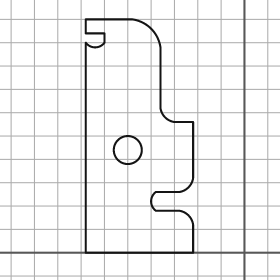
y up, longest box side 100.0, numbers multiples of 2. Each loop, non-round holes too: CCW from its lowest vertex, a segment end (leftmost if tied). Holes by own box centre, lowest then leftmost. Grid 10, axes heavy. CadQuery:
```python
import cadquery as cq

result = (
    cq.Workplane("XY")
    .moveTo(-68.0, 0.0)
    .lineTo(-22.0, 0.0)
    .lineTo(-22.0, 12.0)
    .threePointArc((-24.0, 16.0), (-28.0, 18.0))
    .lineTo(-38.0, 18.0)
    .threePointArc((-40.0, 22.0), (-38.0, 26.0))
    .lineTo(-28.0, 26.0)
    .threePointArc((-24.0, 28.0), (-22.0, 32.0))
    .lineTo(-22.0, 56.0)
    .lineTo(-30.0, 56.0)
    .threePointArc((-34.0, 58.0), (-36.0, 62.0))
    .lineTo(-36.0, 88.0)
    .threePointArc((-40.0, 96.0), (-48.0, 100.0))
    .lineTo(-68.0, 100.0)
    .lineTo(-68.0, 94.0)
    .lineTo(-60.0, 94.0)
    .lineTo(-60.0, 90.0)
    .threePointArc((-64.0, 88.0), (-68.0, 90.0))
    .close()
    .moveTo(-50.0, 44.0)
    .circle(6.0)
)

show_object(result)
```